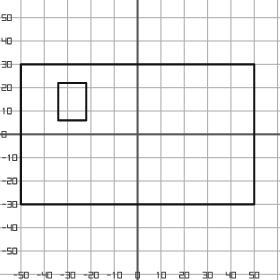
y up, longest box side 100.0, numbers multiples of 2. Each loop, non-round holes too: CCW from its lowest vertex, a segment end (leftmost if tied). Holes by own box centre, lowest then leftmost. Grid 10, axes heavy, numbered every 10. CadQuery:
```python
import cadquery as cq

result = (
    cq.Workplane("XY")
    .moveTo(-50.0, -30.0)
    .lineTo(50.0, -30.0)
    .lineTo(50.0, 30.0)
    .lineTo(-50.0, 30.0)
    .close()
    .moveTo(-34.0, 6.0)
    .lineTo(-22.0, 6.0)
    .lineTo(-22.0, 22.0)
    .lineTo(-34.0, 22.0)
    .close()
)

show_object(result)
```